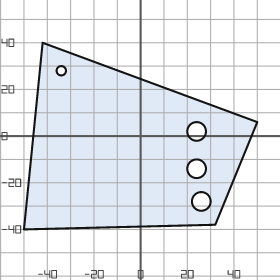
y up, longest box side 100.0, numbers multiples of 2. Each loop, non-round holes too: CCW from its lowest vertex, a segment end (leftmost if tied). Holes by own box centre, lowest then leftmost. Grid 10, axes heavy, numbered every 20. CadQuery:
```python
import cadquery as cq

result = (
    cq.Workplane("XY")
    .moveTo(-50.0, -40.0)
    .lineTo(32.0, -38.0)
    .lineTo(50.0, 6.0)
    .lineTo(-42.0, 40.0)
    .close()
    .moveTo(26.0, -28.0)
    .circle(4.0)
    .moveTo(24.0, -14.0)
    .circle(4.0)
    .moveTo(24.0, 2.0)
    .circle(4.0)
    .moveTo(-34.0, 28.0)
    .circle(2.0)
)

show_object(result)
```